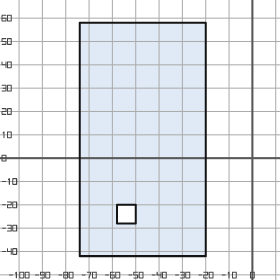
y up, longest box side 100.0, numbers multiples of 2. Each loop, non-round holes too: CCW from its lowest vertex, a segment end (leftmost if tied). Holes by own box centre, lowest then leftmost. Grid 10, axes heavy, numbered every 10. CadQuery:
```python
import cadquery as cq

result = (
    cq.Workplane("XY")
    .moveTo(-74.0, -42.0)
    .lineTo(-20.0, -42.0)
    .lineTo(-20.0, 58.0)
    .lineTo(-74.0, 58.0)
    .close()
    .moveTo(-58.0, -28.0)
    .lineTo(-50.0, -28.0)
    .lineTo(-50.0, -20.0)
    .lineTo(-58.0, -20.0)
    .close()
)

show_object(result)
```